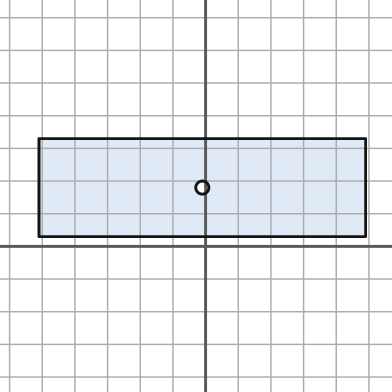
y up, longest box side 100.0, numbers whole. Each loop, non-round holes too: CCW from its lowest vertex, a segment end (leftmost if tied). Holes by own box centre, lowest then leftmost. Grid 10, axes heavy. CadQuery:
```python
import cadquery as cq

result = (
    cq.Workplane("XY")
    .moveTo(-51.0, 3.0)
    .lineTo(49.0, 3.0)
    .lineTo(49.0, 33.0)
    .lineTo(-51.0, 33.0)
    .close()
    .moveTo(-1.0, 18.0)
    .circle(2.0)
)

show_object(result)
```